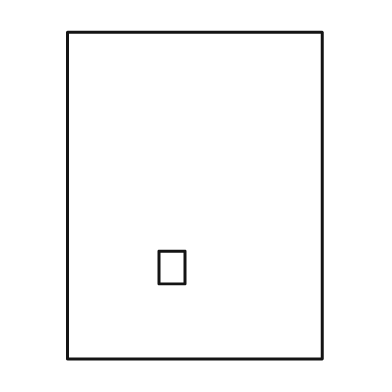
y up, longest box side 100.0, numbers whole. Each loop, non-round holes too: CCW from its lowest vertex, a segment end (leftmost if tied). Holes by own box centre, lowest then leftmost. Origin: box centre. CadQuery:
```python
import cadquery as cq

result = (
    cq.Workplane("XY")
    .moveTo(-39.0, -50.0)
    .lineTo(39.0, -50.0)
    .lineTo(39.0, 50.0)
    .lineTo(-39.0, 50.0)
    .close()
    .moveTo(-11.0, -27.0)
    .lineTo(-3.0, -27.0)
    .lineTo(-3.0, -17.0)
    .lineTo(-11.0, -17.0)
    .close()
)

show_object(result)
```